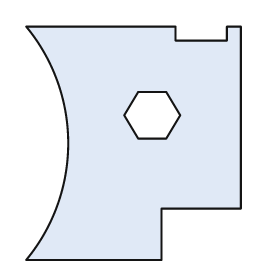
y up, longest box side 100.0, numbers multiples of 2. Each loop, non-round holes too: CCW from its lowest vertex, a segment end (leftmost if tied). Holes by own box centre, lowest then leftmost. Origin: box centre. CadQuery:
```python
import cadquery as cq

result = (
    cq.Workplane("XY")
    .moveTo(-46.0, -50.0)
    .lineTo(12.0, -50.0)
    .lineTo(12.0, -28.0)
    .lineTo(46.0, -28.0)
    .lineTo(46.0, 50.0)
    .lineTo(40.0, 50.0)
    .lineTo(40.0, 44.0)
    .lineTo(18.0, 44.0)
    .lineTo(18.0, 50.0)
    .lineTo(-46.0, 50.0)
    .threePointArc((-28.0, 0.0), (-46.0, -50.0))
    .close()
    .moveTo(2.0, 2.0)
    .lineTo(14.0, 2.0)
    .lineTo(20.0, 12.0)
    .lineTo(14.0, 22.0)
    .lineTo(2.0, 22.0)
    .lineTo(-4.0, 12.0)
    .close()
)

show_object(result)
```